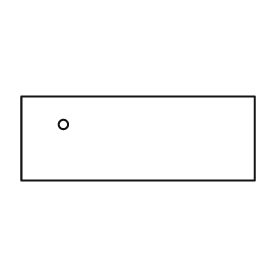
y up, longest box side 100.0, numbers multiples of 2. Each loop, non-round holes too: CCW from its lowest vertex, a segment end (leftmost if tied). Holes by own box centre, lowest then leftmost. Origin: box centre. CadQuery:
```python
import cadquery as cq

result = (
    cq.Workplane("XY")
    .moveTo(-50.0, -18.0)
    .lineTo(50.0, -18.0)
    .lineTo(50.0, 18.0)
    .lineTo(-50.0, 18.0)
    .close()
    .moveTo(-32.0, 6.0)
    .circle(2.0)
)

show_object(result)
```